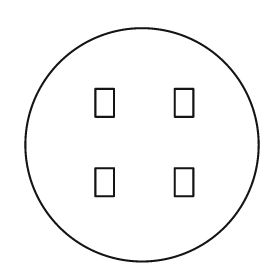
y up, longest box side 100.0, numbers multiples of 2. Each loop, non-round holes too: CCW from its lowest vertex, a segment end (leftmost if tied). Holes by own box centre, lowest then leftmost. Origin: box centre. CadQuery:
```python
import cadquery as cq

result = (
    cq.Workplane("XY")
    .moveTo(0.0, 0.0)
    .circle(50.0)
    .moveTo(-20.0, -22.0)
    .lineTo(-12.0, -22.0)
    .lineTo(-12.0, -10.0)
    .lineTo(-20.0, -10.0)
    .close()
    .moveTo(14.0, -22.0)
    .lineTo(22.0, -22.0)
    .lineTo(22.0, -10.0)
    .lineTo(14.0, -10.0)
    .close()
    .moveTo(-20.0, 12.0)
    .lineTo(-12.0, 12.0)
    .lineTo(-12.0, 24.0)
    .lineTo(-20.0, 24.0)
    .close()
    .moveTo(14.0, 12.0)
    .lineTo(22.0, 12.0)
    .lineTo(22.0, 24.0)
    .lineTo(14.0, 24.0)
    .close()
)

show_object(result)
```